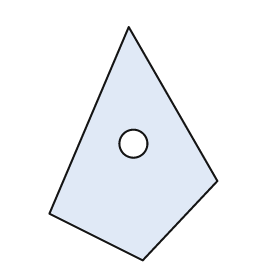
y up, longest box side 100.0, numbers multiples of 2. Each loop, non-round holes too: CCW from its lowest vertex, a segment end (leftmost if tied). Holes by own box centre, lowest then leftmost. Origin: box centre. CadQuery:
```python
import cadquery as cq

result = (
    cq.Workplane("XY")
    .moveTo(4.0, -50.0)
    .lineTo(36.0, -16.0)
    .lineTo(-2.0, 50.0)
    .lineTo(-36.0, -30.0)
    .close()
    .moveTo(0.0, 0.0)
    .circle(6.0)
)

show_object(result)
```